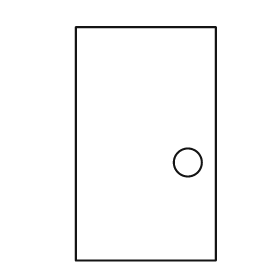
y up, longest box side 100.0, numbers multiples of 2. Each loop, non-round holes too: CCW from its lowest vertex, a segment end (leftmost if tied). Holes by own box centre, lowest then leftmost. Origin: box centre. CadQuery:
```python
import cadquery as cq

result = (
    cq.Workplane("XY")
    .moveTo(-30.0, -50.0)
    .lineTo(30.0, -50.0)
    .lineTo(30.0, 50.0)
    .lineTo(-30.0, 50.0)
    .close()
    .moveTo(18.0, -8.0)
    .circle(6.0)
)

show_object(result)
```